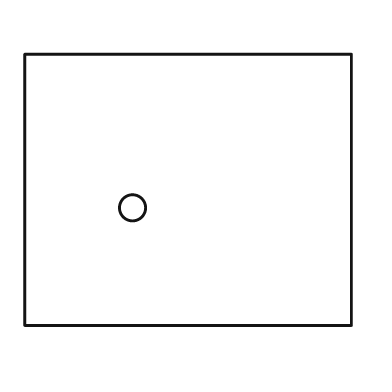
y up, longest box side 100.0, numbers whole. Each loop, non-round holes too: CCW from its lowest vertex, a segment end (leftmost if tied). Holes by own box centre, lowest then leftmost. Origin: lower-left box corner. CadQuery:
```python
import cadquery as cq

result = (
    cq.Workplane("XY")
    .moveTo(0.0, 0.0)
    .lineTo(100.0, 0.0)
    .lineTo(100.0, 83.0)
    .lineTo(0.0, 83.0)
    .close()
    .moveTo(33.0, 36.0)
    .circle(4.0)
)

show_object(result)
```